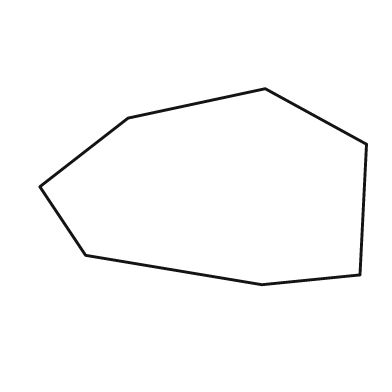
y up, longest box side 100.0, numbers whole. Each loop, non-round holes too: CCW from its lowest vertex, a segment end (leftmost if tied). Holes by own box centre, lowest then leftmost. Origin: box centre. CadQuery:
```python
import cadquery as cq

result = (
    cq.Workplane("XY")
    .moveTo(18.0, -30.0)
    .lineTo(48.0, -27.0)
    .lineTo(50.0, 13.0)
    .lineTo(19.0, 30.0)
    .lineTo(-23.0, 21.0)
    .lineTo(-50.0, 0.0)
    .lineTo(-36.0, -21.0)
    .close()
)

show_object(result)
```